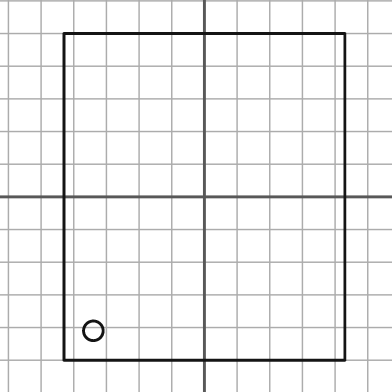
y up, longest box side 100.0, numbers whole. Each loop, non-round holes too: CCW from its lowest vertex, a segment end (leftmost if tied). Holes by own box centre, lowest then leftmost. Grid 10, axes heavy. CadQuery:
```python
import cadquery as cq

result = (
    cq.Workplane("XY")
    .moveTo(-43.0, -50.0)
    .lineTo(43.0, -50.0)
    .lineTo(43.0, 50.0)
    .lineTo(-43.0, 50.0)
    .close()
    .moveTo(-34.0, -41.0)
    .circle(3.0)
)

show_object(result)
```